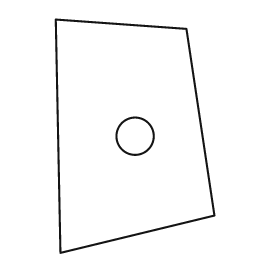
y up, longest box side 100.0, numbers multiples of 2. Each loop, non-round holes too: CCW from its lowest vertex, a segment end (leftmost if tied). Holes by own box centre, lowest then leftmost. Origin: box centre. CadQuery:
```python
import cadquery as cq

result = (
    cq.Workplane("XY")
    .moveTo(-32.0, -50.0)
    .lineTo(34.0, -34.0)
    .lineTo(22.0, 46.0)
    .lineTo(-34.0, 50.0)
    .close()
    .moveTo(0.0, 0.0)
    .circle(8.0)
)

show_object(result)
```